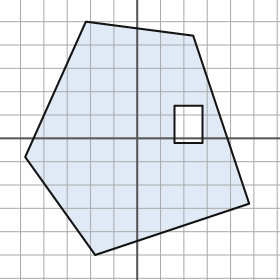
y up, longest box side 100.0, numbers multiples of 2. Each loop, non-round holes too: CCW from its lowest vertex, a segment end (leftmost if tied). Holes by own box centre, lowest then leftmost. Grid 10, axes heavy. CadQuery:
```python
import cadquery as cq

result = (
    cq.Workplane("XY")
    .moveTo(-18.0, -50.0)
    .lineTo(48.0, -28.0)
    .lineTo(24.0, 44.0)
    .lineTo(-22.0, 50.0)
    .lineTo(-48.0, -8.0)
    .close()
    .moveTo(16.0, -2.0)
    .lineTo(28.0, -2.0)
    .lineTo(28.0, 14.0)
    .lineTo(16.0, 14.0)
    .close()
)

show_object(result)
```